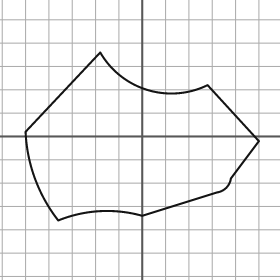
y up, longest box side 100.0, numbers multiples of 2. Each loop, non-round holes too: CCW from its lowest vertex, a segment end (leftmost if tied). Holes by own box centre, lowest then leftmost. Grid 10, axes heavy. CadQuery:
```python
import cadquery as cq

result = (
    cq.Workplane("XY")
    .moveTo(-36.0, -36.0)
    .threePointArc((-18.0, -32.0), (0.0, -34.0))
    .lineTo(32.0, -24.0)
    .threePointArc((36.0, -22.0), (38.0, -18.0))
    .lineTo(50.0, -2.0)
    .lineTo(28.0, 22.0)
    .threePointArc((2.0, 20.0), (-18.0, 36.0))
    .lineTo(-50.0, 2.0)
    .threePointArc((-46.0, -18.0), (-36.0, -36.0))
    .close()
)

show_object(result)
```